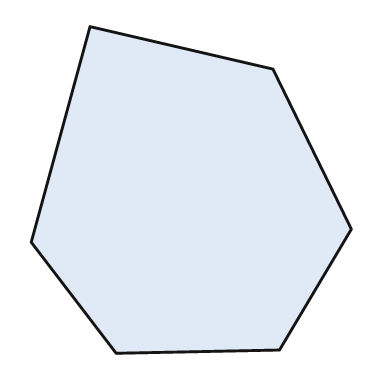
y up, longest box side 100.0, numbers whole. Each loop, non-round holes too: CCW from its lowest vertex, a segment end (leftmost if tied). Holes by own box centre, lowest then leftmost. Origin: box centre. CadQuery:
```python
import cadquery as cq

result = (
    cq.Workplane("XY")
    .moveTo(-23.0, -50.0)
    .lineTo(27.0, -49.0)
    .lineTo(49.0, -12.0)
    .lineTo(25.0, 37.0)
    .lineTo(-31.0, 50.0)
    .lineTo(-49.0, -16.0)
    .close()
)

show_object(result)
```